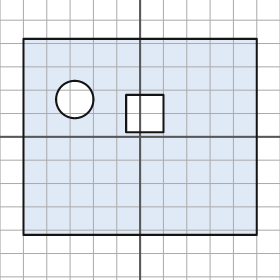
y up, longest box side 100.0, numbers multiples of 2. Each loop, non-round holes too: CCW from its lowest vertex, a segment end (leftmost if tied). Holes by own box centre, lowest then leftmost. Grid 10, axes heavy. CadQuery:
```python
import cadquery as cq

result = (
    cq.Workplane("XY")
    .moveTo(-50.0, -42.0)
    .lineTo(50.0, -42.0)
    .lineTo(50.0, 42.0)
    .lineTo(-50.0, 42.0)
    .close()
    .moveTo(-6.0, 2.0)
    .lineTo(10.0, 2.0)
    .lineTo(10.0, 18.0)
    .lineTo(-6.0, 18.0)
    .close()
    .moveTo(-28.0, 16.0)
    .circle(8.0)
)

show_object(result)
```